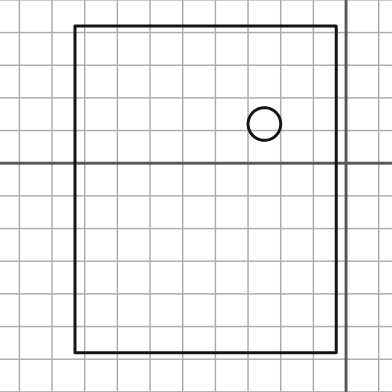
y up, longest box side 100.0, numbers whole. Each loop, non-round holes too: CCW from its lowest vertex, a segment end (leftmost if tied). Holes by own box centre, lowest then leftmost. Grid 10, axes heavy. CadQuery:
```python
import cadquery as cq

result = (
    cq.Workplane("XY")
    .moveTo(-83.0, -58.0)
    .lineTo(-3.0, -58.0)
    .lineTo(-3.0, 42.0)
    .lineTo(-83.0, 42.0)
    .close()
    .moveTo(-25.0, 12.0)
    .circle(5.0)
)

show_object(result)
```